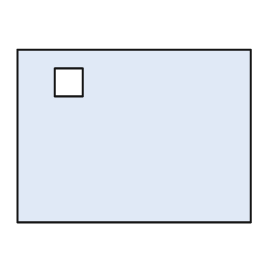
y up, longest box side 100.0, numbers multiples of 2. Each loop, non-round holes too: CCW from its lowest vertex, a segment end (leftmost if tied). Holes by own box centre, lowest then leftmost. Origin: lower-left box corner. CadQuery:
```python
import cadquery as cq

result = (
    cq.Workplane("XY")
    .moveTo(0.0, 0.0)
    .lineTo(100.0, 0.0)
    .lineTo(100.0, 74.0)
    .lineTo(0.0, 74.0)
    .close()
    .moveTo(16.0, 54.0)
    .lineTo(28.0, 54.0)
    .lineTo(28.0, 66.0)
    .lineTo(16.0, 66.0)
    .close()
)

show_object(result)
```